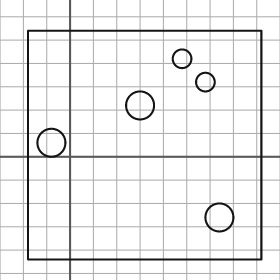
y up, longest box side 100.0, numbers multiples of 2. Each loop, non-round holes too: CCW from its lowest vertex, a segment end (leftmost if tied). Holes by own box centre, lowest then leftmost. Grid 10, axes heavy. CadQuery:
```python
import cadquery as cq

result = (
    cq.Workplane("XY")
    .moveTo(-18.0, -44.0)
    .lineTo(82.0, -44.0)
    .lineTo(82.0, 54.0)
    .lineTo(-18.0, 54.0)
    .close()
    .moveTo(64.0, -26.0)
    .circle(6.0)
    .moveTo(-8.0, 6.0)
    .circle(6.0)
    .moveTo(30.0, 22.0)
    .circle(6.0)
    .moveTo(58.0, 32.0)
    .circle(4.0)
    .moveTo(48.0, 42.0)
    .circle(4.0)
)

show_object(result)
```